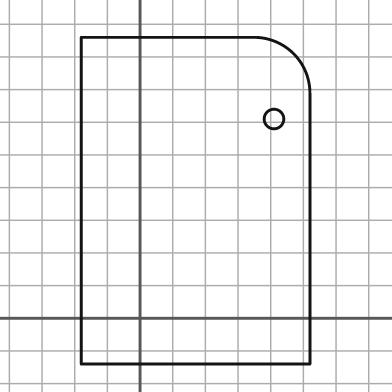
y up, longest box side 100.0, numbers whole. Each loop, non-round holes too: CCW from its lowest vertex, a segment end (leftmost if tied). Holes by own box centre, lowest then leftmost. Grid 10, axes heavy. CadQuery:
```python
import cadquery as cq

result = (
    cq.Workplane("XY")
    .moveTo(-18.0, -14.0)
    .lineTo(52.0, -14.0)
    .lineTo(52.0, 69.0)
    .threePointArc((47.0, 81.0), (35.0, 86.0))
    .lineTo(-18.0, 86.0)
    .close()
    .moveTo(41.0, 61.0)
    .circle(3.0)
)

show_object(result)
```